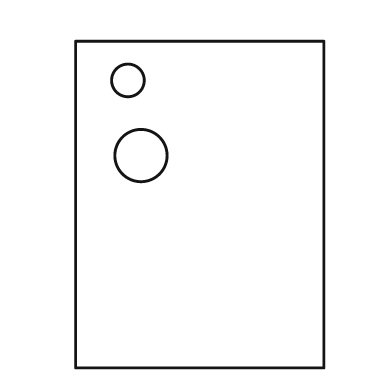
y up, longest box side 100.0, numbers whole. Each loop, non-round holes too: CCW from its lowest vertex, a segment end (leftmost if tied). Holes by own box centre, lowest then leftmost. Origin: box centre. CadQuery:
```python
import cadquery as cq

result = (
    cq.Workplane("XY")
    .moveTo(-38.0, -50.0)
    .lineTo(38.0, -50.0)
    .lineTo(38.0, 50.0)
    .lineTo(-38.0, 50.0)
    .close()
    .moveTo(-18.0, 15.0)
    .circle(8.0)
    .moveTo(-22.0, 38.0)
    .circle(5.0)
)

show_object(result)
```